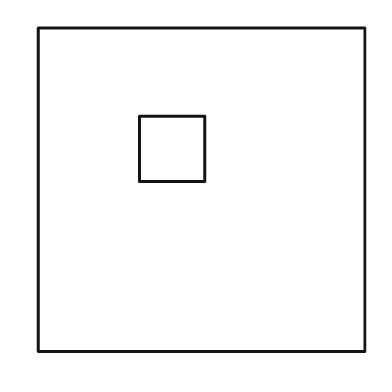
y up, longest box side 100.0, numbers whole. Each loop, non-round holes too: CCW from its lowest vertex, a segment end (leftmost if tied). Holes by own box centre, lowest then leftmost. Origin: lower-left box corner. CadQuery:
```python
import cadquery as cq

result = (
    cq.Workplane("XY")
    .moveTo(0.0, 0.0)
    .lineTo(100.0, 0.0)
    .lineTo(100.0, 99.0)
    .lineTo(0.0, 99.0)
    .close()
    .moveTo(31.0, 52.0)
    .lineTo(51.0, 52.0)
    .lineTo(51.0, 72.0)
    .lineTo(31.0, 72.0)
    .close()
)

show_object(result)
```